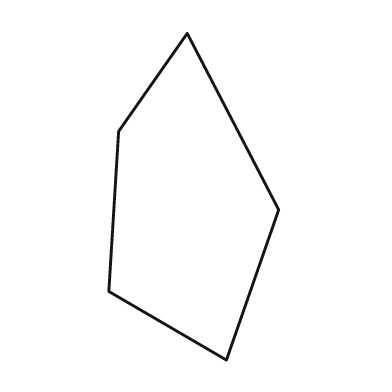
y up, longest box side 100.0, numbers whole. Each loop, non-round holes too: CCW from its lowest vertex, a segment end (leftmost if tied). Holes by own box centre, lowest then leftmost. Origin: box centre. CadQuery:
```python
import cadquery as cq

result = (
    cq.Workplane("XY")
    .moveTo(10.0, -50.0)
    .lineTo(26.0, -4.0)
    .lineTo(-2.0, 50.0)
    .lineTo(-23.0, 20.0)
    .lineTo(-26.0, -29.0)
    .close()
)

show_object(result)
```